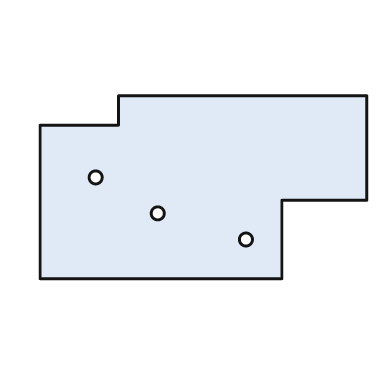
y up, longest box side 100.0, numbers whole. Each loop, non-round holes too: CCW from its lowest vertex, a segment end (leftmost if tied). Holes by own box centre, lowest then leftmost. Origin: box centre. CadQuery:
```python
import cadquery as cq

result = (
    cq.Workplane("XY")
    .moveTo(-50.0, -28.0)
    .lineTo(24.0, -28.0)
    .lineTo(24.0, -4.0)
    .lineTo(50.0, -4.0)
    .lineTo(50.0, 28.0)
    .lineTo(-26.0, 28.0)
    .lineTo(-26.0, 19.0)
    .lineTo(-50.0, 19.0)
    .close()
    .moveTo(13.0, -16.0)
    .circle(2.0)
    .moveTo(-14.0, -8.0)
    .circle(2.0)
    .moveTo(-33.0, 3.0)
    .circle(2.0)
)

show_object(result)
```